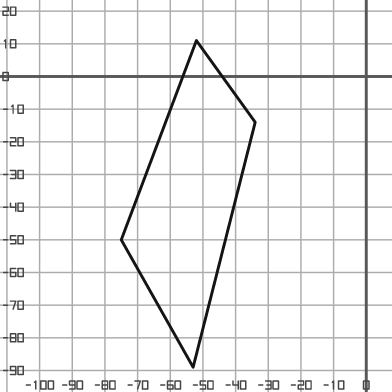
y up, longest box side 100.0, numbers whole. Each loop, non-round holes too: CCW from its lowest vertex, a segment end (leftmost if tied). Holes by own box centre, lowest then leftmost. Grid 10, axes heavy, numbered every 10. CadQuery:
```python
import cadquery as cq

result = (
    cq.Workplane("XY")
    .moveTo(-53.0, -89.0)
    .lineTo(-34.0, -14.0)
    .lineTo(-52.0, 11.0)
    .lineTo(-75.0, -50.0)
    .close()
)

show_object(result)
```